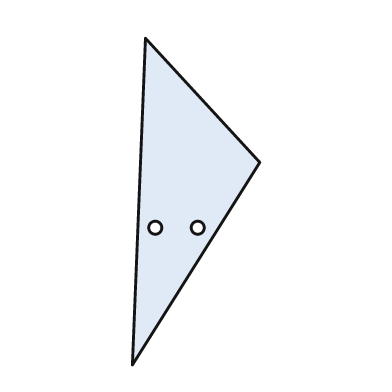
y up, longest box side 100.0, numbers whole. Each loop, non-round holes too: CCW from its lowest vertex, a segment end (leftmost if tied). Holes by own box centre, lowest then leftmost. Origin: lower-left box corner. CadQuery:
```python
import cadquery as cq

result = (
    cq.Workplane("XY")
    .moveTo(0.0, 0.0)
    .lineTo(39.0, 62.0)
    .lineTo(4.0, 100.0)
    .close()
    .moveTo(7.0, 42.0)
    .circle(2.0)
    .moveTo(20.0, 42.0)
    .circle(2.0)
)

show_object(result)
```